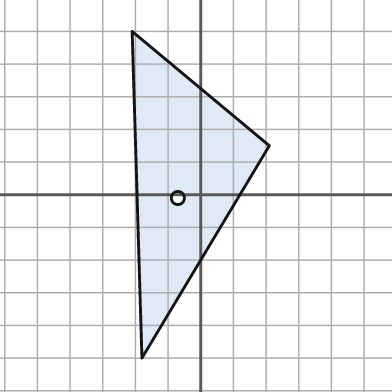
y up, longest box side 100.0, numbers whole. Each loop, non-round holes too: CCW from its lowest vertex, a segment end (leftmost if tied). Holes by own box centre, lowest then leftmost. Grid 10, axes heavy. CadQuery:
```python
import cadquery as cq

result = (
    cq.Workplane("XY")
    .moveTo(-18.0, -50.0)
    .lineTo(21.0, 15.0)
    .lineTo(-21.0, 50.0)
    .close()
    .moveTo(-7.0, -1.0)
    .circle(2.0)
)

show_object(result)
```